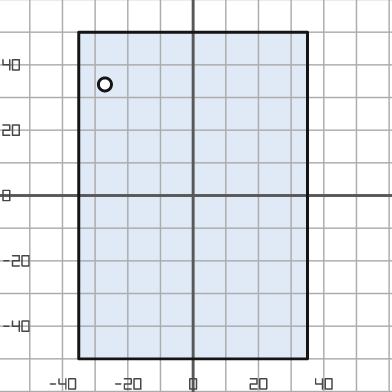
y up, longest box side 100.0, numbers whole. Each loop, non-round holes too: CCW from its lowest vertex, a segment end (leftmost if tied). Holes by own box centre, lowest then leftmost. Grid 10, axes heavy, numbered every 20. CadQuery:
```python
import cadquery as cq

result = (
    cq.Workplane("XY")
    .moveTo(-35.0, -50.0)
    .lineTo(35.0, -50.0)
    .lineTo(35.0, 50.0)
    .lineTo(-35.0, 50.0)
    .close()
    .moveTo(-27.0, 34.0)
    .circle(2.0)
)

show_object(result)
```